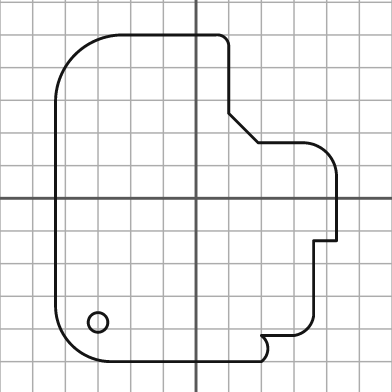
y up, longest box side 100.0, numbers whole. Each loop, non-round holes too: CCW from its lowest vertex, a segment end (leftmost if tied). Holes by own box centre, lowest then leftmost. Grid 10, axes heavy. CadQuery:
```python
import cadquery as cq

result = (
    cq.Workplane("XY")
    .moveTo(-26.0, -50.0)
    .lineTo(20.0, -50.0)
    .threePointArc((22.0, -46.0), (20.0, -42.0))
    .lineTo(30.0, -42.0)
    .threePointArc((34.0, -40.0), (36.0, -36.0))
    .lineTo(36.0, -13.0)
    .lineTo(43.0, -13.0)
    .lineTo(43.0, 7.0)
    .threePointArc((40.0, 14.0), (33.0, 17.0))
    .lineTo(19.0, 17.0)
    .lineTo(10.0, 26.0)
    .lineTo(10.0, 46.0)
    .threePointArc((9.0, 49.0), (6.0, 50.0))
    .lineTo(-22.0, 50.0)
    .threePointArc((-37.0, 44.0), (-43.0, 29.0))
    .lineTo(-43.0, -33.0)
    .threePointArc((-38.0, -45.0), (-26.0, -50.0))
    .close()
    .moveTo(-30.0, -38.0)
    .circle(3.0)
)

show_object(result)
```